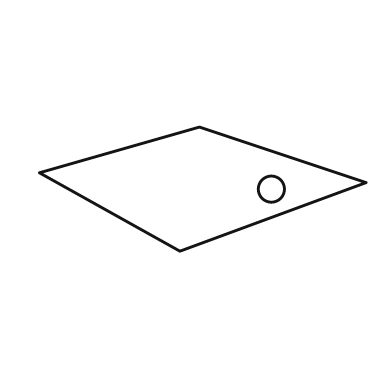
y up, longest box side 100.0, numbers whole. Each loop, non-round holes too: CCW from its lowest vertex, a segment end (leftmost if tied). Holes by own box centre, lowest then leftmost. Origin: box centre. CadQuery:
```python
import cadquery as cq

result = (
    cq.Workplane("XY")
    .moveTo(-7.0, -19.0)
    .lineTo(50.0, 2.0)
    .lineTo(-1.0, 19.0)
    .lineTo(-50.0, 5.0)
    .close()
    .moveTo(21.0, 0.0)
    .circle(4.0)
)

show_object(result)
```